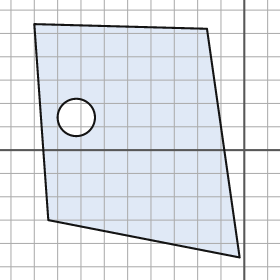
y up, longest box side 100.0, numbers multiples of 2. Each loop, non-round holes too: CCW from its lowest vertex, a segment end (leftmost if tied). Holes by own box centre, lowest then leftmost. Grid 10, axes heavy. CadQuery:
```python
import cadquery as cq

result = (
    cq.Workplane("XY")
    .moveTo(-2.0, -46.0)
    .lineTo(-16.0, 52.0)
    .lineTo(-90.0, 54.0)
    .lineTo(-84.0, -30.0)
    .close()
    .moveTo(-72.0, 14.0)
    .circle(8.0)
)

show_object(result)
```